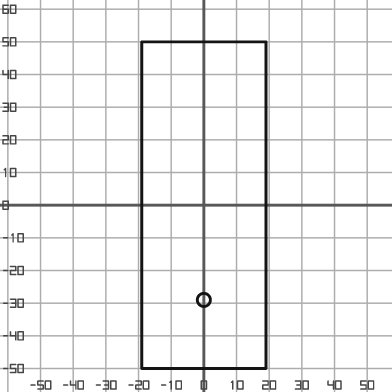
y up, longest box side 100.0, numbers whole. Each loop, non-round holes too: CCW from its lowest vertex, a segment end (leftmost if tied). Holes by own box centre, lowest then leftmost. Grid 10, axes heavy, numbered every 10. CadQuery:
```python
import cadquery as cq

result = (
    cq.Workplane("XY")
    .moveTo(-19.0, -50.0)
    .lineTo(19.0, -50.0)
    .lineTo(19.0, 50.0)
    .lineTo(-19.0, 50.0)
    .close()
    .moveTo(0.0, -29.0)
    .circle(2.0)
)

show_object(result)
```